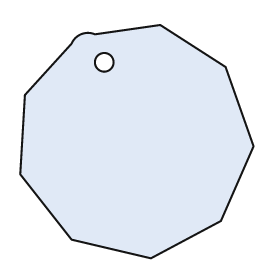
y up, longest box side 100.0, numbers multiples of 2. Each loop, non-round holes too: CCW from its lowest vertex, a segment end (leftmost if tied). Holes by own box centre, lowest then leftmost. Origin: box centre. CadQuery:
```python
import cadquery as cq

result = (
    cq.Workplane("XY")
    .moveTo(6.0, -50.0)
    .lineTo(36.0, -34.0)
    .lineTo(50.0, -2.0)
    .lineTo(38.0, 32.0)
    .lineTo(10.0, 50.0)
    .lineTo(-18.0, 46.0)
    .threePointArc((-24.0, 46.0), (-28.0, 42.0))
    .lineTo(-48.0, 20.0)
    .lineTo(-50.0, -14.0)
    .lineTo(-28.0, -42.0)
    .close()
    .moveTo(-14.0, 34.0)
    .circle(4.0)
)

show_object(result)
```